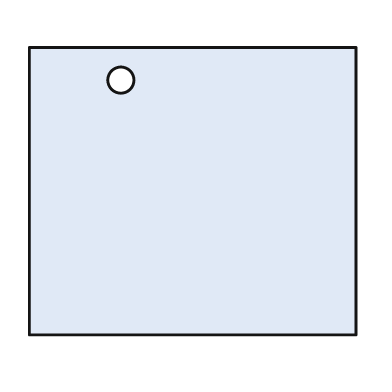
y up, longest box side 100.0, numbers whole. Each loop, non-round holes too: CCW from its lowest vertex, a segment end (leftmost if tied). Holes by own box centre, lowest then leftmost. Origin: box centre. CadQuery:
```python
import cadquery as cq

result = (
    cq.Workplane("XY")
    .moveTo(-50.0, -44.0)
    .lineTo(50.0, -44.0)
    .lineTo(50.0, 44.0)
    .lineTo(-50.0, 44.0)
    .close()
    .moveTo(-22.0, 34.0)
    .circle(4.0)
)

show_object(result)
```